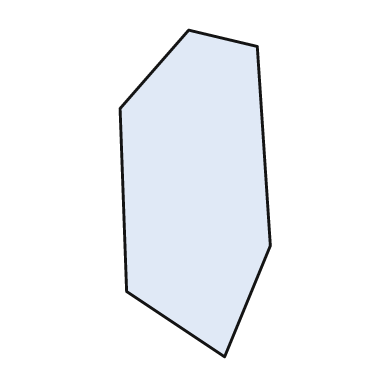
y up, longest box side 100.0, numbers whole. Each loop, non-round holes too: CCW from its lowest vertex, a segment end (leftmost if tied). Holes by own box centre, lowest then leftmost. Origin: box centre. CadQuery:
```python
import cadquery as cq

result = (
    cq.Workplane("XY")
    .moveTo(9.0, -50.0)
    .lineTo(23.0, -16.0)
    .lineTo(19.0, 45.0)
    .lineTo(-2.0, 50.0)
    .lineTo(-23.0, 26.0)
    .lineTo(-21.0, -30.0)
    .close()
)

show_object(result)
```